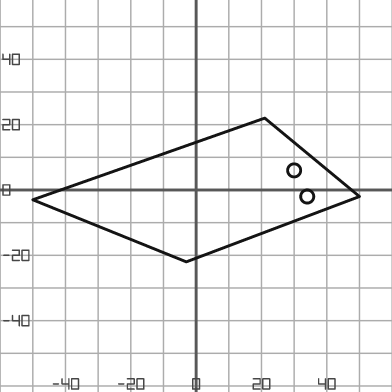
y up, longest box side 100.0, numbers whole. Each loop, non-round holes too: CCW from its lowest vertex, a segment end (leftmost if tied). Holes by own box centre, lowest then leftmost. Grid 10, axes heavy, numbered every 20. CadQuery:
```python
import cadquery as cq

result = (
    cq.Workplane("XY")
    .moveTo(-3.0, -22.0)
    .lineTo(50.0, -2.0)
    .lineTo(21.0, 22.0)
    .lineTo(-50.0, -3.0)
    .close()
    .moveTo(34.0, -2.0)
    .circle(2.0)
    .moveTo(30.0, 6.0)
    .circle(2.0)
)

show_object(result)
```